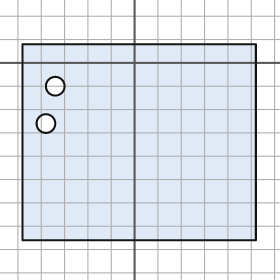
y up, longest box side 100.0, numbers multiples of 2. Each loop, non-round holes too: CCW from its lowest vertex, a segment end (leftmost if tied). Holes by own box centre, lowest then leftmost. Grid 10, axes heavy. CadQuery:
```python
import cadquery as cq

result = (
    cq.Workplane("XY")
    .moveTo(-48.0, -76.0)
    .lineTo(52.0, -76.0)
    .lineTo(52.0, 8.0)
    .lineTo(-48.0, 8.0)
    .close()
    .moveTo(-38.0, -26.0)
    .circle(4.0)
    .moveTo(-34.0, -10.0)
    .circle(4.0)
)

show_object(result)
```